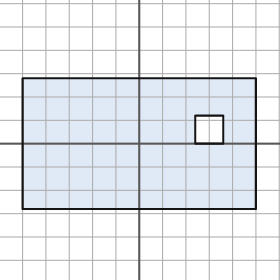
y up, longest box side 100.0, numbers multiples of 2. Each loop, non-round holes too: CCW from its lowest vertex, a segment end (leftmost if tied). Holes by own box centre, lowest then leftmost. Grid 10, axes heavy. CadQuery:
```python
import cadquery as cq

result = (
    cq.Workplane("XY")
    .moveTo(-50.0, -28.0)
    .lineTo(50.0, -28.0)
    .lineTo(50.0, 28.0)
    .lineTo(-50.0, 28.0)
    .close()
    .moveTo(24.0, 0.0)
    .lineTo(36.0, 0.0)
    .lineTo(36.0, 12.0)
    .lineTo(24.0, 12.0)
    .close()
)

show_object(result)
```